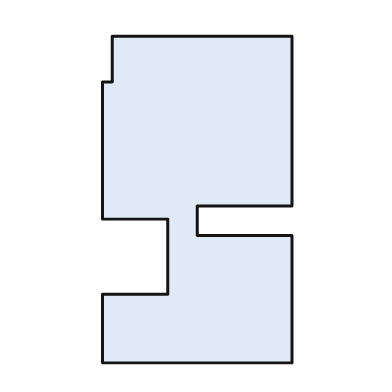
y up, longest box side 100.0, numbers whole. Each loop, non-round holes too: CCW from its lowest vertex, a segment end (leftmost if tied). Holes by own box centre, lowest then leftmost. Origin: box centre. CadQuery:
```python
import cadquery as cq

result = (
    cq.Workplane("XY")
    .moveTo(-29.0, -50.0)
    .lineTo(29.0, -50.0)
    .lineTo(29.0, -11.0)
    .lineTo(0.0, -11.0)
    .lineTo(0.0, -2.0)
    .lineTo(29.0, -2.0)
    .lineTo(29.0, 50.0)
    .lineTo(-26.0, 50.0)
    .lineTo(-26.0, 36.0)
    .lineTo(-29.0, 36.0)
    .lineTo(-29.0, -6.0)
    .lineTo(-9.0, -6.0)
    .lineTo(-9.0, -29.0)
    .lineTo(-29.0, -29.0)
    .close()
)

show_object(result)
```